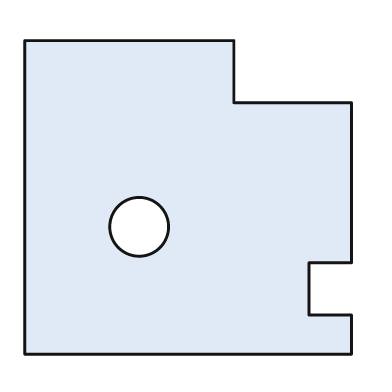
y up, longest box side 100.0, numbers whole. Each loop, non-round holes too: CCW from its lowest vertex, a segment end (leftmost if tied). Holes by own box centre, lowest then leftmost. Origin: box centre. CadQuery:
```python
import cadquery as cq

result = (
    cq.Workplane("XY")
    .moveTo(-50.0, -48.0)
    .lineTo(50.0, -48.0)
    .lineTo(50.0, -36.0)
    .lineTo(37.0, -36.0)
    .lineTo(37.0, -20.0)
    .lineTo(50.0, -20.0)
    .lineTo(50.0, 29.0)
    .lineTo(14.0, 29.0)
    .lineTo(14.0, 48.0)
    .lineTo(-50.0, 48.0)
    .close()
    .moveTo(-15.0, -9.0)
    .circle(9.0)
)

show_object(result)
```